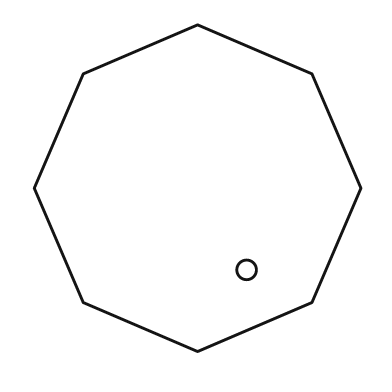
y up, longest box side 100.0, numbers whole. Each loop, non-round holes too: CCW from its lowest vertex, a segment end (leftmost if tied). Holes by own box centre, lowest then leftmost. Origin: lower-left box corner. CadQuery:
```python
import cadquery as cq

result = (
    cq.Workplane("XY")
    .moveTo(50.0, 0.0)
    .lineTo(85.0, 15.0)
    .lineTo(100.0, 50.0)
    .lineTo(85.0, 85.0)
    .lineTo(50.0, 100.0)
    .lineTo(15.0, 85.0)
    .lineTo(0.0, 50.0)
    .lineTo(15.0, 15.0)
    .close()
    .moveTo(65.0, 25.0)
    .circle(3.0)
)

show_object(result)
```